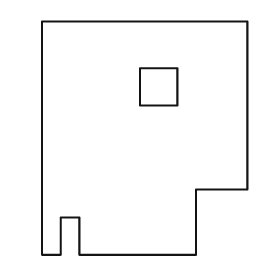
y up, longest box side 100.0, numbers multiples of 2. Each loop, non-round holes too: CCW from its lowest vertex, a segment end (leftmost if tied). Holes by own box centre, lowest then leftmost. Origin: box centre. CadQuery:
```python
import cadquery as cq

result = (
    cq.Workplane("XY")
    .moveTo(-44.0, -50.0)
    .lineTo(-36.0, -50.0)
    .lineTo(-36.0, -34.0)
    .lineTo(-28.0, -34.0)
    .lineTo(-28.0, -50.0)
    .lineTo(22.0, -50.0)
    .lineTo(22.0, -22.0)
    .lineTo(44.0, -22.0)
    .lineTo(44.0, 50.0)
    .lineTo(-44.0, 50.0)
    .close()
    .moveTo(-2.0, 14.0)
    .lineTo(14.0, 14.0)
    .lineTo(14.0, 30.0)
    .lineTo(-2.0, 30.0)
    .close()
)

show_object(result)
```